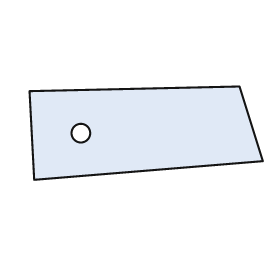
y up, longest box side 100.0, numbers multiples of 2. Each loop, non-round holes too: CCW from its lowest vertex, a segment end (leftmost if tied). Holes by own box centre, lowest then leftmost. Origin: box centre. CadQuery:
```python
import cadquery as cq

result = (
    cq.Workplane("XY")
    .moveTo(-48.0, -20.0)
    .lineTo(50.0, -12.0)
    .lineTo(40.0, 20.0)
    .lineTo(-50.0, 18.0)
    .close()
    .moveTo(-28.0, 0.0)
    .circle(4.0)
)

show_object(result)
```